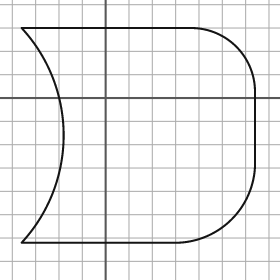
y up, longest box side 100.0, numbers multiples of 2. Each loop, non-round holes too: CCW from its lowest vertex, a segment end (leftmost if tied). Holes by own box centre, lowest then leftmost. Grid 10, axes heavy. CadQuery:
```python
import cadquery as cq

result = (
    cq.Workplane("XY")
    .moveTo(-36.0, -62.0)
    .lineTo(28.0, -62.0)
    .threePointArc((54.0, -52.0), (64.0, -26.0))
    .lineTo(64.0, 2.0)
    .threePointArc((56.0, 22.0), (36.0, 30.0))
    .lineTo(-36.0, 30.0)
    .threePointArc((-18.0, -16.0), (-36.0, -62.0))
    .close()
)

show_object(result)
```